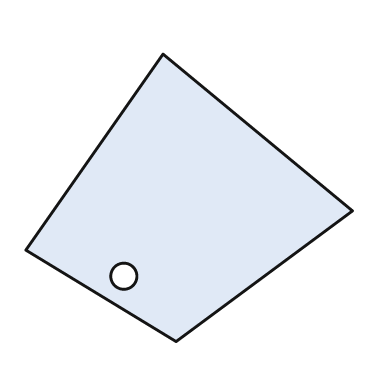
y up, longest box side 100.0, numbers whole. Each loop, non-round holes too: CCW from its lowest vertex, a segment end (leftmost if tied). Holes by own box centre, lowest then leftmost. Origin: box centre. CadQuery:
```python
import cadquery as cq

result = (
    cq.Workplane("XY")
    .moveTo(-4.0, -44.0)
    .lineTo(50.0, -4.0)
    .lineTo(-8.0, 44.0)
    .lineTo(-50.0, -16.0)
    .close()
    .moveTo(-20.0, -24.0)
    .circle(4.0)
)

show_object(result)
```